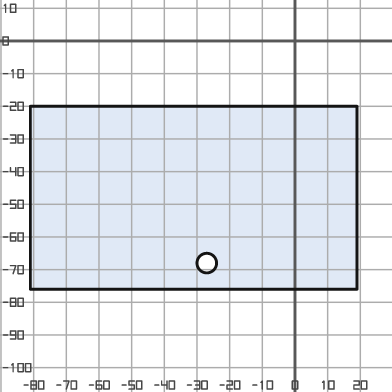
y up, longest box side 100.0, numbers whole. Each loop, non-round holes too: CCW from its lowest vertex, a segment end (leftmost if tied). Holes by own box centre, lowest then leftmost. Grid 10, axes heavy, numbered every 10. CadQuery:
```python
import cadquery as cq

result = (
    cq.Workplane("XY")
    .moveTo(-81.0, -76.0)
    .lineTo(19.0, -76.0)
    .lineTo(19.0, -20.0)
    .lineTo(-81.0, -20.0)
    .close()
    .moveTo(-27.0, -68.0)
    .circle(3.0)
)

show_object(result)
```